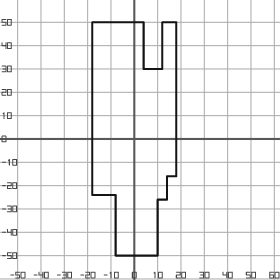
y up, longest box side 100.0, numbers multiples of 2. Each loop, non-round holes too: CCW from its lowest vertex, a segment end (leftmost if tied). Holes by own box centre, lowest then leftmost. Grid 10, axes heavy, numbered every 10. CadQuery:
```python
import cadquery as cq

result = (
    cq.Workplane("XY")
    .moveTo(-8.0, -50.0)
    .lineTo(10.0, -50.0)
    .lineTo(10.0, -26.0)
    .lineTo(14.0, -26.0)
    .lineTo(14.0, -16.0)
    .lineTo(18.0, -16.0)
    .lineTo(18.0, 50.0)
    .lineTo(12.0, 50.0)
    .lineTo(12.0, 30.0)
    .lineTo(4.0, 30.0)
    .lineTo(4.0, 50.0)
    .lineTo(-18.0, 50.0)
    .lineTo(-18.0, -24.0)
    .lineTo(-8.0, -24.0)
    .close()
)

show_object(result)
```